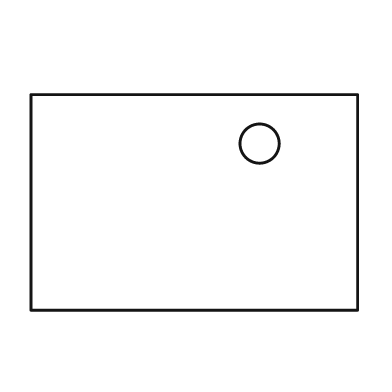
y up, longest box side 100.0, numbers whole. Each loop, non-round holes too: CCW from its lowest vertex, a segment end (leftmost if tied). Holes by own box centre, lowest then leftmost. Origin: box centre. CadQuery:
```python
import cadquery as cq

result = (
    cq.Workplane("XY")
    .moveTo(-50.0, -33.0)
    .lineTo(50.0, -33.0)
    .lineTo(50.0, 33.0)
    .lineTo(-50.0, 33.0)
    .close()
    .moveTo(20.0, 18.0)
    .circle(6.0)
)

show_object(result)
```